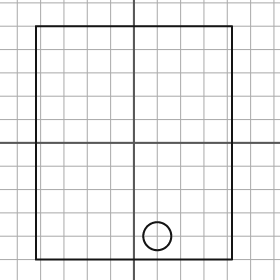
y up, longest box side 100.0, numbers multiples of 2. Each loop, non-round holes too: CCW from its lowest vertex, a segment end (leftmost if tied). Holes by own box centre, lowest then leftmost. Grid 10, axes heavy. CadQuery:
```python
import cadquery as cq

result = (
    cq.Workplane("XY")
    .moveTo(-42.0, -50.0)
    .lineTo(42.0, -50.0)
    .lineTo(42.0, 50.0)
    .lineTo(-42.0, 50.0)
    .close()
    .moveTo(10.0, -40.0)
    .circle(6.0)
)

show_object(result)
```